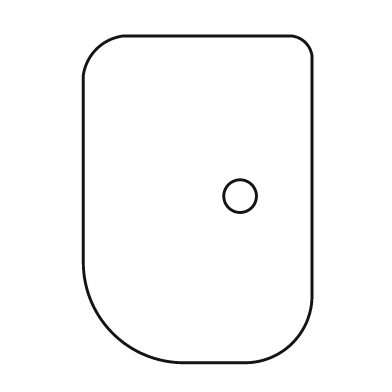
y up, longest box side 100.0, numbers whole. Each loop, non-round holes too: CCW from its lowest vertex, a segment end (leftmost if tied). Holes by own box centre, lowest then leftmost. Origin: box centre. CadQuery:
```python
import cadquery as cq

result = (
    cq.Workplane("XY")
    .moveTo(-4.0, -50.0)
    .lineTo(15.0, -50.0)
    .threePointArc((29.0, -44.0), (35.0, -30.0))
    .lineTo(35.0, 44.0)
    .threePointArc((33.0, 48.0), (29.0, 50.0))
    .lineTo(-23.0, 50.0)
    .threePointArc((-31.0, 46.0), (-35.0, 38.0))
    .lineTo(-35.0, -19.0)
    .threePointArc((-26.0, -41.0), (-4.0, -50.0))
    .close()
    .moveTo(13.0, 1.0)
    .circle(5.0)
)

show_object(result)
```